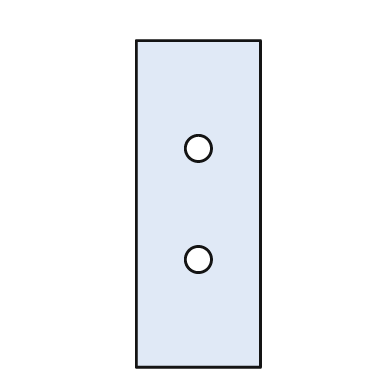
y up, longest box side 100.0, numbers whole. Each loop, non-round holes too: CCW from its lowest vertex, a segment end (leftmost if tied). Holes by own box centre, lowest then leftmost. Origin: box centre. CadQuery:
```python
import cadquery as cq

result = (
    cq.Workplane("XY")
    .moveTo(-19.0, -50.0)
    .lineTo(19.0, -50.0)
    .lineTo(19.0, 50.0)
    .lineTo(-19.0, 50.0)
    .close()
    .moveTo(0.0, -17.0)
    .circle(4.0)
    .moveTo(0.0, 17.0)
    .circle(4.0)
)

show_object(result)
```